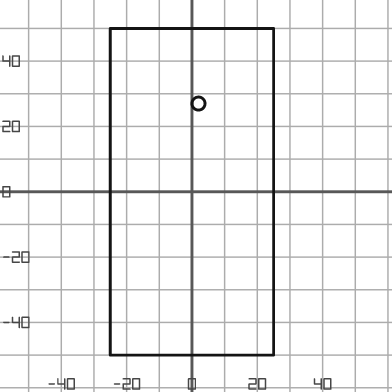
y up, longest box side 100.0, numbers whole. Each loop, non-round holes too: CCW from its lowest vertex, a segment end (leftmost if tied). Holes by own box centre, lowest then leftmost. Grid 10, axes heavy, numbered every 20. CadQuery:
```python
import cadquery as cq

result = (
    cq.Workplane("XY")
    .moveTo(-25.0, -50.0)
    .lineTo(25.0, -50.0)
    .lineTo(25.0, 50.0)
    .lineTo(-25.0, 50.0)
    .close()
    .moveTo(2.0, 27.0)
    .circle(2.0)
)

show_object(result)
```